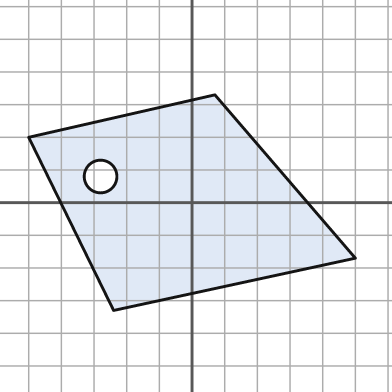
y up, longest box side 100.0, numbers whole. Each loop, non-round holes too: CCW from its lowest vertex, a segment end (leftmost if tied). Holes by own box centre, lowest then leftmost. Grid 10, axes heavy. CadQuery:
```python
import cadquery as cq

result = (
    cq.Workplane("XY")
    .moveTo(-24.0, -33.0)
    .lineTo(50.0, -17.0)
    .lineTo(7.0, 33.0)
    .lineTo(-50.0, 20.0)
    .close()
    .moveTo(-28.0, 8.0)
    .circle(5.0)
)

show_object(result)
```